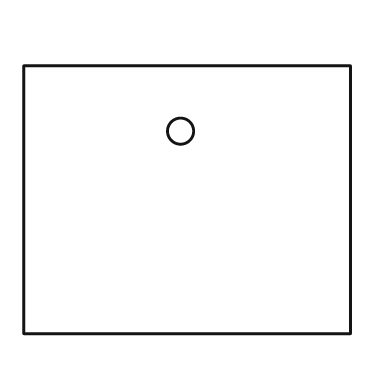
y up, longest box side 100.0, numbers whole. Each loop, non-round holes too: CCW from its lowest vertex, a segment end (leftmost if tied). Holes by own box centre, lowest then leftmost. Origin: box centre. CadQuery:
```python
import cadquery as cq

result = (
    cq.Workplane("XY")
    .moveTo(-50.0, -41.0)
    .lineTo(50.0, -41.0)
    .lineTo(50.0, 41.0)
    .lineTo(-50.0, 41.0)
    .close()
    .moveTo(-2.0, 21.0)
    .circle(4.0)
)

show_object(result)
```